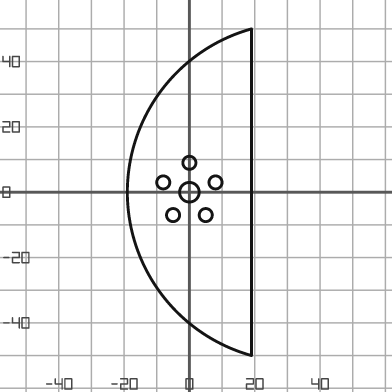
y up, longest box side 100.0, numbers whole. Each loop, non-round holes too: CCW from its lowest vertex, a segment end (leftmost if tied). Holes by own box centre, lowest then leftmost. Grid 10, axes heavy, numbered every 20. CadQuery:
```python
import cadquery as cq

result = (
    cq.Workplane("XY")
    .moveTo(19.0, -50.0)
    .lineTo(19.0, 50.0)
    .threePointArc((-19.0, 0.0), (19.0, -50.0))
    .close()
    .moveTo(-5.0, -7.0)
    .circle(2.0)
    .moveTo(5.0, -7.0)
    .circle(2.0)
    .moveTo(0.0, 0.0)
    .circle(3.0)
    .moveTo(-8.0, 3.0)
    .circle(2.0)
    .moveTo(8.0, 3.0)
    .circle(2.0)
    .moveTo(0.0, 9.0)
    .circle(2.0)
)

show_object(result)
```